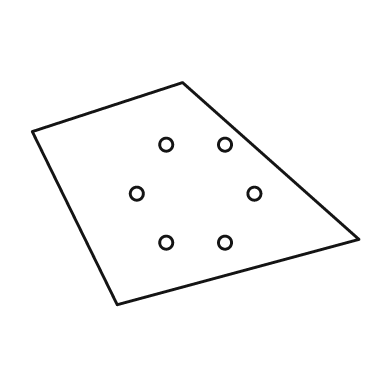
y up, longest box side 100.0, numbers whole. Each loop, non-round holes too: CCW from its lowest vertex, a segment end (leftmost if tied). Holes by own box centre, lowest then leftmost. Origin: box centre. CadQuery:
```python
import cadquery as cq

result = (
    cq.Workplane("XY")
    .moveTo(-24.0, -34.0)
    .lineTo(50.0, -14.0)
    .lineTo(-4.0, 34.0)
    .lineTo(-50.0, 19.0)
    .close()
    .moveTo(-9.0, -15.0)
    .circle(2.0)
    .moveTo(9.0, -15.0)
    .circle(2.0)
    .moveTo(-18.0, 0.0)
    .circle(2.0)
    .moveTo(18.0, 0.0)
    .circle(2.0)
    .moveTo(-9.0, 15.0)
    .circle(2.0)
    .moveTo(9.0, 15.0)
    .circle(2.0)
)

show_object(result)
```